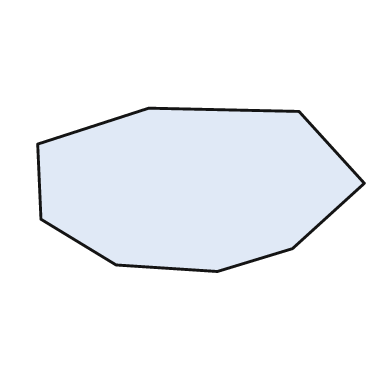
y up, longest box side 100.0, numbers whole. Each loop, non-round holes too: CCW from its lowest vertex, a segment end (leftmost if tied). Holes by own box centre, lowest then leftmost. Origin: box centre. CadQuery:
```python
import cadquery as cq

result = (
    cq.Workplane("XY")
    .moveTo(5.0, -25.0)
    .lineTo(28.0, -18.0)
    .lineTo(50.0, 2.0)
    .lineTo(30.0, 24.0)
    .lineTo(-16.0, 25.0)
    .lineTo(-50.0, 14.0)
    .lineTo(-49.0, -9.0)
    .lineTo(-26.0, -23.0)
    .close()
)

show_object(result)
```